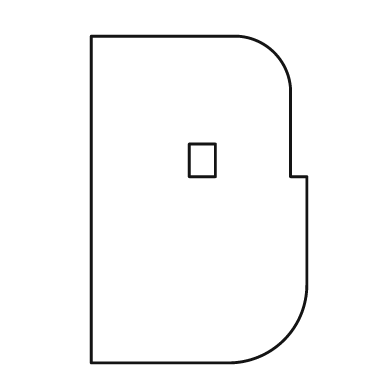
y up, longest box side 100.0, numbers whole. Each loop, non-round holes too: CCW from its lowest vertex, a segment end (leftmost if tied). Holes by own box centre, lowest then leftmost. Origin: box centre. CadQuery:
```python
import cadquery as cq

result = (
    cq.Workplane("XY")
    .moveTo(-33.0, -50.0)
    .lineTo(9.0, -50.0)
    .threePointArc((26.0, -43.0), (33.0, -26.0))
    .lineTo(33.0, 7.0)
    .lineTo(28.0, 7.0)
    .lineTo(28.0, 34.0)
    .threePointArc((23.0, 45.0), (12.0, 50.0))
    .lineTo(-33.0, 50.0)
    .close()
    .moveTo(-3.0, 7.0)
    .lineTo(5.0, 7.0)
    .lineTo(5.0, 17.0)
    .lineTo(-3.0, 17.0)
    .close()
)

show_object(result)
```